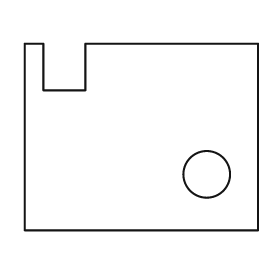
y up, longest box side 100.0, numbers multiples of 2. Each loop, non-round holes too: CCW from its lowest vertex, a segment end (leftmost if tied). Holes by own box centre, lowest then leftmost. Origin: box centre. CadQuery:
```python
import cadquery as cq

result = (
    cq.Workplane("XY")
    .moveTo(-50.0, -40.0)
    .lineTo(50.0, -40.0)
    .lineTo(50.0, 40.0)
    .lineTo(-24.0, 40.0)
    .lineTo(-24.0, 20.0)
    .lineTo(-42.0, 20.0)
    .lineTo(-42.0, 40.0)
    .lineTo(-50.0, 40.0)
    .close()
    .moveTo(28.0, -16.0)
    .circle(10.0)
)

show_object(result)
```